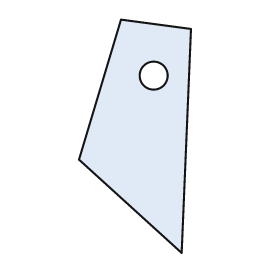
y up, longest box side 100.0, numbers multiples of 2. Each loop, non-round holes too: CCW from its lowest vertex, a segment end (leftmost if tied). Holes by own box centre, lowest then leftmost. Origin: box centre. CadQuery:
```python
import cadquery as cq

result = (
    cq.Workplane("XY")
    .moveTo(20.0, -50.0)
    .lineTo(24.0, 46.0)
    .lineTo(-6.0, 50.0)
    .lineTo(-24.0, -10.0)
    .close()
    .moveTo(8.0, 26.0)
    .circle(6.0)
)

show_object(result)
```